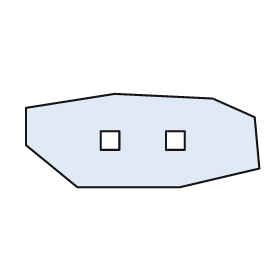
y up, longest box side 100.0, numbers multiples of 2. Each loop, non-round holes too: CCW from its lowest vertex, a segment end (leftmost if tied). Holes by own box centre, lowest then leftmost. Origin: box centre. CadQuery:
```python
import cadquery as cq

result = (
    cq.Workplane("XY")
    .moveTo(-28.0, -20.0)
    .lineTo(16.0, -20.0)
    .lineTo(50.0, -12.0)
    .lineTo(48.0, 10.0)
    .lineTo(30.0, 18.0)
    .lineTo(-12.0, 20.0)
    .lineTo(-50.0, 14.0)
    .lineTo(-50.0, -2.0)
    .close()
    .moveTo(-18.0, -4.0)
    .lineTo(-10.0, -4.0)
    .lineTo(-10.0, 4.0)
    .lineTo(-18.0, 4.0)
    .close()
    .moveTo(10.0, -4.0)
    .lineTo(18.0, -4.0)
    .lineTo(18.0, 4.0)
    .lineTo(10.0, 4.0)
    .close()
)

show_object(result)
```